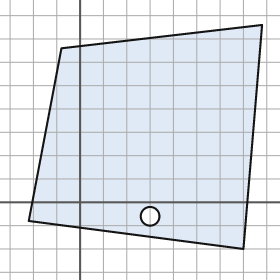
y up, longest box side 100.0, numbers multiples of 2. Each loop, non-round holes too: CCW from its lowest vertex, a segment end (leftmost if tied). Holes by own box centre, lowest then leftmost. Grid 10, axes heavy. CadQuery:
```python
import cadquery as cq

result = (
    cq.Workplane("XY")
    .moveTo(70.0, -20.0)
    .lineTo(78.0, 76.0)
    .lineTo(-8.0, 66.0)
    .lineTo(-22.0, -8.0)
    .close()
    .moveTo(30.0, -6.0)
    .circle(4.0)
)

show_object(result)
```